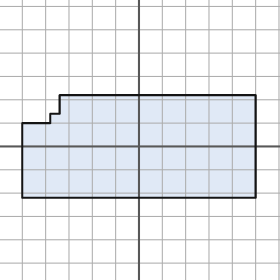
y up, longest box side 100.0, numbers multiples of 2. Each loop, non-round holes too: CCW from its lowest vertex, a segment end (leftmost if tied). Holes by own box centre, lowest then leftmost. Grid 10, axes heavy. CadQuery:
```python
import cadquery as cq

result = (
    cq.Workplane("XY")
    .moveTo(-50.0, -22.0)
    .lineTo(50.0, -22.0)
    .lineTo(50.0, 22.0)
    .lineTo(-34.0, 22.0)
    .lineTo(-34.0, 14.0)
    .lineTo(-38.0, 14.0)
    .lineTo(-38.0, 10.0)
    .lineTo(-50.0, 10.0)
    .close()
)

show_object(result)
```